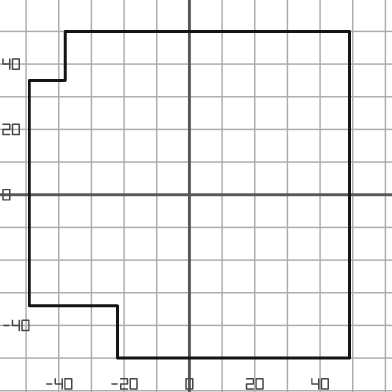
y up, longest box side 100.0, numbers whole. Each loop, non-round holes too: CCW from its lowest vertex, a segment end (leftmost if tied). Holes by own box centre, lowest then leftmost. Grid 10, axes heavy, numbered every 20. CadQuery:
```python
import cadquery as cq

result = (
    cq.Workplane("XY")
    .moveTo(-22.0, -50.0)
    .lineTo(49.0, -50.0)
    .lineTo(49.0, 50.0)
    .lineTo(-38.0, 50.0)
    .lineTo(-38.0, 35.0)
    .lineTo(-49.0, 35.0)
    .lineTo(-49.0, -34.0)
    .lineTo(-22.0, -34.0)
    .close()
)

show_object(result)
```